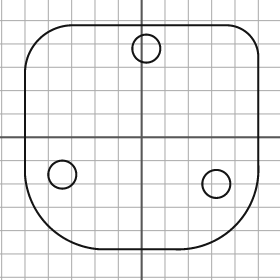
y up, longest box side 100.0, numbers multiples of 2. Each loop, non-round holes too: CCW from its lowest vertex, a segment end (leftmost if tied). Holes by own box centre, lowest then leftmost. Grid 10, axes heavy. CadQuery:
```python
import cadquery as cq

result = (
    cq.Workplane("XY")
    .moveTo(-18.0, -48.0)
    .lineTo(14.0, -48.0)
    .threePointArc((40.0, -38.0), (50.0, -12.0))
    .lineTo(50.0, 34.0)
    .threePointArc((46.0, 44.0), (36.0, 48.0))
    .lineTo(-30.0, 48.0)
    .threePointArc((-44.0, 42.0), (-50.0, 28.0))
    .lineTo(-50.0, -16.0)
    .threePointArc((-40.0, -38.0), (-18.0, -48.0))
    .close()
    .moveTo(32.0, -20.0)
    .circle(6.0)
    .moveTo(-34.0, -16.0)
    .circle(6.0)
    .moveTo(2.0, 38.0)
    .circle(6.0)
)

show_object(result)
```